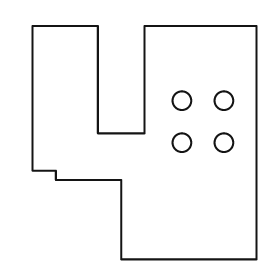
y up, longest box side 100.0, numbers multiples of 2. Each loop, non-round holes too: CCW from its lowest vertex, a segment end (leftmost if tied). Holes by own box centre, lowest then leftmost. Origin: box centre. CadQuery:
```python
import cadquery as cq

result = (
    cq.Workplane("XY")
    .moveTo(-10.0, -50.0)
    .lineTo(48.0, -50.0)
    .lineTo(48.0, 50.0)
    .lineTo(0.0, 50.0)
    .lineTo(0.0, 4.0)
    .lineTo(-20.0, 4.0)
    .lineTo(-20.0, 50.0)
    .lineTo(-48.0, 50.0)
    .lineTo(-48.0, -12.0)
    .lineTo(-38.0, -12.0)
    .lineTo(-38.0, -16.0)
    .lineTo(-10.0, -16.0)
    .close()
    .moveTo(16.0, 0.0)
    .circle(4.0)
    .moveTo(34.0, 0.0)
    .circle(4.0)
    .moveTo(16.0, 18.0)
    .circle(4.0)
    .moveTo(34.0, 18.0)
    .circle(4.0)
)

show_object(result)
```